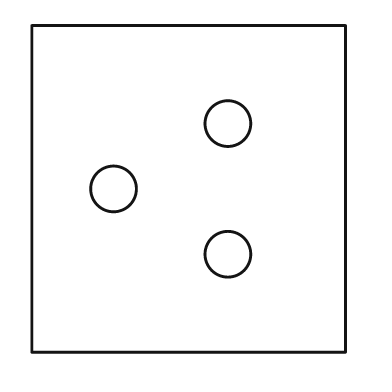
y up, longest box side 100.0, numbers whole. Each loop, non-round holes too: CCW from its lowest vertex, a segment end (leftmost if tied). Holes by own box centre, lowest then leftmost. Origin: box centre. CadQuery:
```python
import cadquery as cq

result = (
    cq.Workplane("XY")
    .moveTo(-48.0, -50.0)
    .lineTo(48.0, -50.0)
    .lineTo(48.0, 50.0)
    .lineTo(-48.0, 50.0)
    .close()
    .moveTo(12.0, -20.0)
    .circle(7.0)
    .moveTo(-23.0, 0.0)
    .circle(7.0)
    .moveTo(12.0, 20.0)
    .circle(7.0)
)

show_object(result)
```